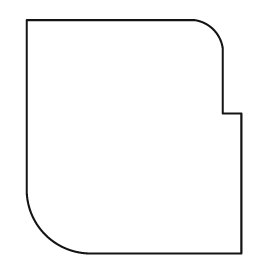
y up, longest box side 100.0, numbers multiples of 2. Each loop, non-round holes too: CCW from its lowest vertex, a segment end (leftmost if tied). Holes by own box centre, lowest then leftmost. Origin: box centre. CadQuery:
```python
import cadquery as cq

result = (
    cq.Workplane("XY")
    .moveTo(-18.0, -50.0)
    .lineTo(46.0, -50.0)
    .lineTo(46.0, 10.0)
    .lineTo(38.0, 10.0)
    .lineTo(38.0, 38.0)
    .threePointArc((34.0, 46.0), (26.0, 50.0))
    .lineTo(-46.0, 50.0)
    .lineTo(-46.0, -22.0)
    .threePointArc((-38.0, -42.0), (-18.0, -50.0))
    .close()
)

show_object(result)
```